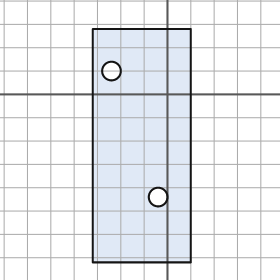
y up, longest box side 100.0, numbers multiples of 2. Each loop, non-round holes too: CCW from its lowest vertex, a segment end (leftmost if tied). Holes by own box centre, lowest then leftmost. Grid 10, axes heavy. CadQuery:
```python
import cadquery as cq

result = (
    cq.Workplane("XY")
    .moveTo(-32.0, -72.0)
    .lineTo(10.0, -72.0)
    .lineTo(10.0, 28.0)
    .lineTo(-32.0, 28.0)
    .close()
    .moveTo(-4.0, -44.0)
    .circle(4.0)
    .moveTo(-24.0, 10.0)
    .circle(4.0)
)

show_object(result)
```